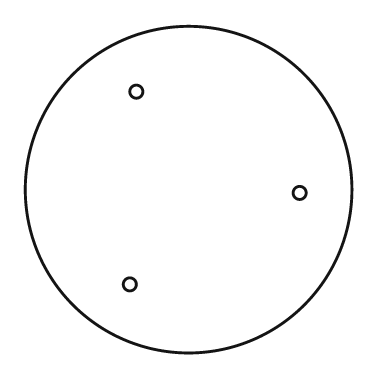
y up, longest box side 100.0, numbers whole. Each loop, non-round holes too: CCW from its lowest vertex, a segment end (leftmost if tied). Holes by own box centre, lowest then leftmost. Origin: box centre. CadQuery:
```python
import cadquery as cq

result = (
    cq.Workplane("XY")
    .moveTo(0.0, 0.0)
    .circle(50.0)
    .moveTo(-18.0, -29.0)
    .circle(2.0)
    .moveTo(34.0, -1.0)
    .circle(2.0)
    .moveTo(-16.0, 30.0)
    .circle(2.0)
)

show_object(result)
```